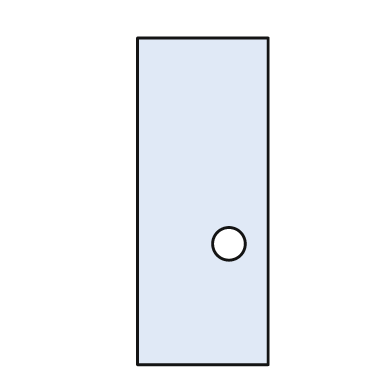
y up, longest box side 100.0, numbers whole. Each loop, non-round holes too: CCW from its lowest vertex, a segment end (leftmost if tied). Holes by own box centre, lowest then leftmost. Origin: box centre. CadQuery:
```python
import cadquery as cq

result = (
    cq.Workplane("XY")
    .moveTo(-20.0, -50.0)
    .lineTo(20.0, -50.0)
    .lineTo(20.0, 50.0)
    .lineTo(-20.0, 50.0)
    .close()
    .moveTo(8.0, -13.0)
    .circle(5.0)
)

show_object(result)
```